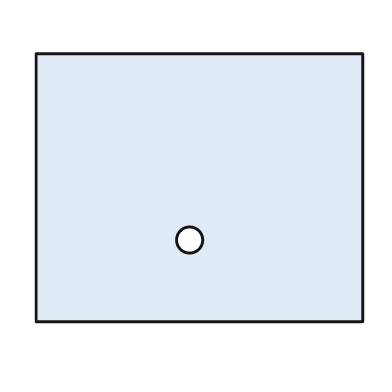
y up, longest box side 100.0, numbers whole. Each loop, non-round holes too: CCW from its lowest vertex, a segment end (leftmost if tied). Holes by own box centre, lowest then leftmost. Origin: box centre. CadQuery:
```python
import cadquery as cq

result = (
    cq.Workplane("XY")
    .moveTo(-50.0, -41.0)
    .lineTo(50.0, -41.0)
    .lineTo(50.0, 41.0)
    .lineTo(-50.0, 41.0)
    .close()
    .moveTo(-3.0, -16.0)
    .circle(4.0)
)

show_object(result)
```